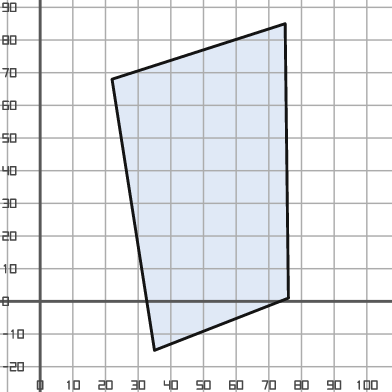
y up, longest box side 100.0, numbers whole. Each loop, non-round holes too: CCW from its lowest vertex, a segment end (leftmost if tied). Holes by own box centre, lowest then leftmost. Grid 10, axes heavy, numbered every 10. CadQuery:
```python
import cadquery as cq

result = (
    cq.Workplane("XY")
    .moveTo(35.0, -15.0)
    .lineTo(76.0, 1.0)
    .lineTo(75.0, 85.0)
    .lineTo(22.0, 68.0)
    .close()
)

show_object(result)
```